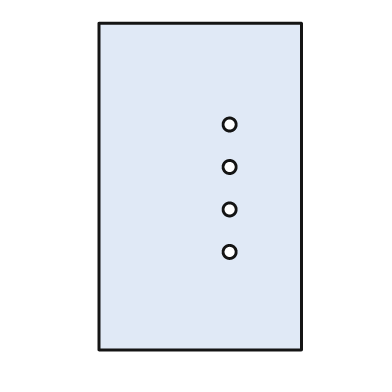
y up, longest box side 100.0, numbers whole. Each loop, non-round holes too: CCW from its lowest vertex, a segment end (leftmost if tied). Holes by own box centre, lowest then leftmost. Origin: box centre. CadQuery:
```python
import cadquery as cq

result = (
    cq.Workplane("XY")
    .moveTo(-31.0, -50.0)
    .lineTo(31.0, -50.0)
    .lineTo(31.0, 50.0)
    .lineTo(-31.0, 50.0)
    .close()
    .moveTo(9.0, -20.0)
    .circle(2.0)
    .moveTo(9.0, -7.0)
    .circle(2.0)
    .moveTo(9.0, 6.0)
    .circle(2.0)
    .moveTo(9.0, 19.0)
    .circle(2.0)
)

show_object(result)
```